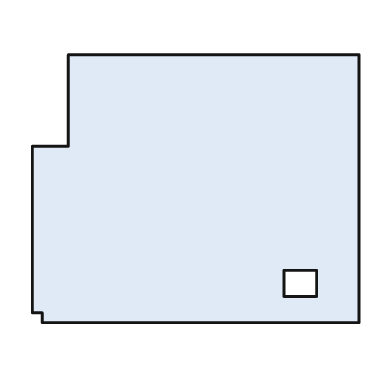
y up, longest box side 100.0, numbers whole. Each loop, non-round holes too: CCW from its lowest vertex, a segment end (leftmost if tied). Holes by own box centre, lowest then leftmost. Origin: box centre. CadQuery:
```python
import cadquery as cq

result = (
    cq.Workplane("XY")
    .moveTo(-47.0, -41.0)
    .lineTo(50.0, -41.0)
    .lineTo(50.0, 41.0)
    .lineTo(-39.0, 41.0)
    .lineTo(-39.0, 13.0)
    .lineTo(-50.0, 13.0)
    .lineTo(-50.0, -38.0)
    .lineTo(-47.0, -38.0)
    .close()
    .moveTo(27.0, -33.0)
    .lineTo(37.0, -33.0)
    .lineTo(37.0, -25.0)
    .lineTo(27.0, -25.0)
    .close()
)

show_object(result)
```